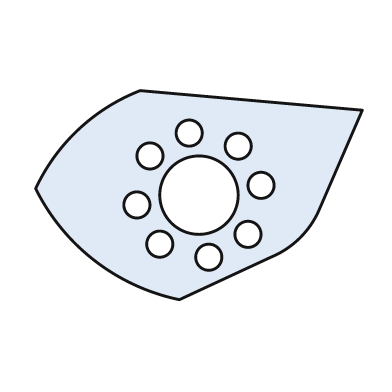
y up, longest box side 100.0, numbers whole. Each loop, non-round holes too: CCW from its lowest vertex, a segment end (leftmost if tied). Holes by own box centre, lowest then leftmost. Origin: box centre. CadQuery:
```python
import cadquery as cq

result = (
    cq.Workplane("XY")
    .moveTo(-6.0, -32.0)
    .lineTo(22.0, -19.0)
    .threePointArc((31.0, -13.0), (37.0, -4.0))
    .lineTo(50.0, 26.0)
    .lineTo(-18.0, 32.0)
    .threePointArc((-37.0, 20.0), (-50.0, 2.0))
    .threePointArc((-32.0, -20.0), (-6.0, -32.0))
    .close()
    .moveTo(3.0, -19.0)
    .circle(4.0)
    .moveTo(-12.0, -15.0)
    .circle(4.0)
    .moveTo(15.0, -12.0)
    .circle(4.0)
    .moveTo(-19.0, -3.0)
    .circle(4.0)
    .moveTo(0.0, 0.0)
    .circle(12.0)
    .moveTo(19.0, 3.0)
    .circle(4.0)
    .moveTo(-15.0, 12.0)
    .circle(4.0)
    .moveTo(12.0, 15.0)
    .circle(4.0)
    .moveTo(-3.0, 19.0)
    .circle(4.0)
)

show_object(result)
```